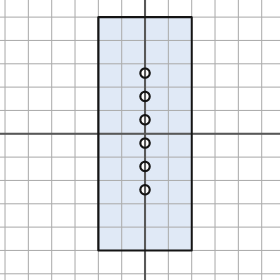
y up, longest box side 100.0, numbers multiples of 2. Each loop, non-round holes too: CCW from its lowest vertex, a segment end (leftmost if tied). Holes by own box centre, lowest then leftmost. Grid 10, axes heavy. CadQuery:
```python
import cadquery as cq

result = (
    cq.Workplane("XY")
    .moveTo(-20.0, -50.0)
    .lineTo(20.0, -50.0)
    .lineTo(20.0, 50.0)
    .lineTo(-20.0, 50.0)
    .close()
    .moveTo(0.0, -24.0)
    .circle(2.0)
    .moveTo(0.0, -14.0)
    .circle(2.0)
    .moveTo(0.0, -4.0)
    .circle(2.0)
    .moveTo(0.0, 6.0)
    .circle(2.0)
    .moveTo(0.0, 16.0)
    .circle(2.0)
    .moveTo(0.0, 26.0)
    .circle(2.0)
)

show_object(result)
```